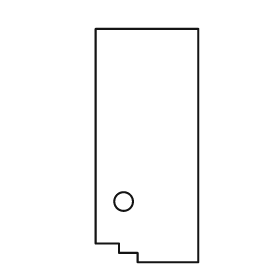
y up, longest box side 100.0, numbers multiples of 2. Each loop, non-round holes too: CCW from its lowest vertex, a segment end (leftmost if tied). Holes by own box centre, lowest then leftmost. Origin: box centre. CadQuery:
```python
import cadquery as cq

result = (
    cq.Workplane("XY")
    .moveTo(-4.0, -50.0)
    .lineTo(22.0, -50.0)
    .lineTo(22.0, 50.0)
    .lineTo(-22.0, 50.0)
    .lineTo(-22.0, -42.0)
    .lineTo(-12.0, -42.0)
    .lineTo(-12.0, -46.0)
    .lineTo(-4.0, -46.0)
    .close()
    .moveTo(-10.0, -24.0)
    .circle(4.0)
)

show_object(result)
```